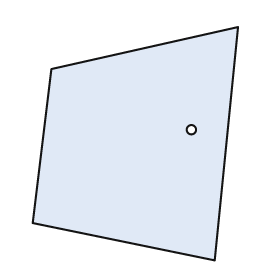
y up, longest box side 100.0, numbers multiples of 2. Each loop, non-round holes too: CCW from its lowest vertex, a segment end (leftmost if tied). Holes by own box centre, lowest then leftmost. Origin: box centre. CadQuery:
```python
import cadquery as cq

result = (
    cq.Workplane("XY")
    .moveTo(34.0, -50.0)
    .lineTo(44.0, 50.0)
    .lineTo(-36.0, 32.0)
    .lineTo(-44.0, -34.0)
    .close()
    .moveTo(24.0, 6.0)
    .circle(2.0)
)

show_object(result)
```